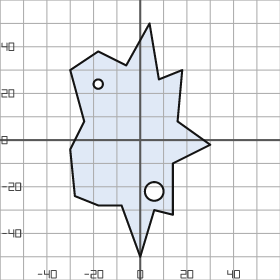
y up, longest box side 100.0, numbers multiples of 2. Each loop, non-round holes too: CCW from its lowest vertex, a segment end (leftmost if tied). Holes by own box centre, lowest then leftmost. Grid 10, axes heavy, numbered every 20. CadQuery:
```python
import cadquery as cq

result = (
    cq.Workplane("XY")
    .moveTo(0.0, -50.0)
    .lineTo(6.0, -30.0)
    .lineTo(14.0, -32.0)
    .lineTo(14.0, -10.0)
    .lineTo(30.0, -2.0)
    .lineTo(16.0, 8.0)
    .lineTo(18.0, 30.0)
    .lineTo(8.0, 26.0)
    .lineTo(4.0, 50.0)
    .lineTo(-6.0, 32.0)
    .lineTo(-18.0, 38.0)
    .lineTo(-30.0, 30.0)
    .lineTo(-24.0, 8.0)
    .lineTo(-30.0, -4.0)
    .lineTo(-28.0, -24.0)
    .lineTo(-18.0, -28.0)
    .lineTo(-8.0, -28.0)
    .close()
    .moveTo(6.0, -22.0)
    .circle(4.0)
    .moveTo(-18.0, 24.0)
    .circle(2.0)
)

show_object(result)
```